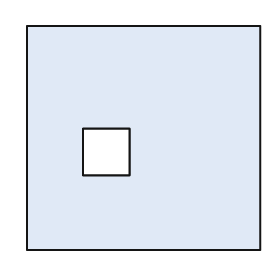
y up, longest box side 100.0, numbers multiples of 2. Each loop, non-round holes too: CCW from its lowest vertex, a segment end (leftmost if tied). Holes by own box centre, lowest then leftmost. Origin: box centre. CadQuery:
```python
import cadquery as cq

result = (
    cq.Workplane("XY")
    .moveTo(-50.0, -48.0)
    .lineTo(50.0, -48.0)
    .lineTo(50.0, 48.0)
    .lineTo(-50.0, 48.0)
    .close()
    .moveTo(-26.0, -16.0)
    .lineTo(-6.0, -16.0)
    .lineTo(-6.0, 4.0)
    .lineTo(-26.0, 4.0)
    .close()
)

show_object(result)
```